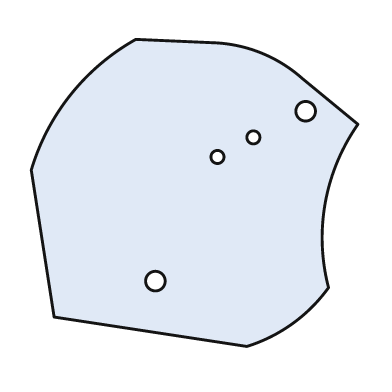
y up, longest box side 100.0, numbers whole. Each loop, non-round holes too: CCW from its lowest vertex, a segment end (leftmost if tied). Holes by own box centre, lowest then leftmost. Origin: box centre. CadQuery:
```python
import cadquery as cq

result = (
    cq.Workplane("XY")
    .moveTo(16.0, -47.0)
    .threePointArc((30.0, -40.0), (41.0, -29.0))
    .threePointArc((40.0, -3.0), (50.0, 21.0))
    .lineTo(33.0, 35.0)
    .threePointArc((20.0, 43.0), (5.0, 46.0))
    .lineTo(-18.0, 47.0)
    .threePointArc((-38.0, 30.0), (-50.0, 7.0))
    .lineTo(-43.0, -38.0)
    .close()
    .moveTo(-12.0, -27.0)
    .circle(3.0)
    .moveTo(7.0, 11.0)
    .circle(2.0)
    .moveTo(18.0, 17.0)
    .circle(2.0)
    .moveTo(34.0, 25.0)
    .circle(3.0)
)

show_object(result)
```